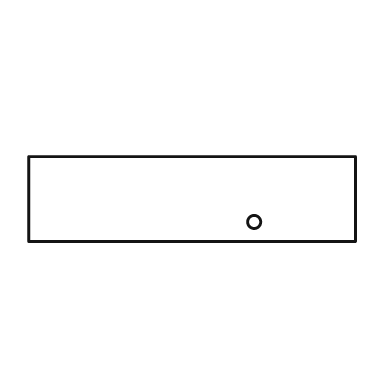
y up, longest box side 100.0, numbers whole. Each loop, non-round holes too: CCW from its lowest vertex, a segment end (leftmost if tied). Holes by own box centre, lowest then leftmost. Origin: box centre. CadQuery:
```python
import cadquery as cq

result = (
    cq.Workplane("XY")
    .moveTo(-50.0, -13.0)
    .lineTo(50.0, -13.0)
    .lineTo(50.0, 13.0)
    .lineTo(-50.0, 13.0)
    .close()
    .moveTo(19.0, -7.0)
    .circle(2.0)
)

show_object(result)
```